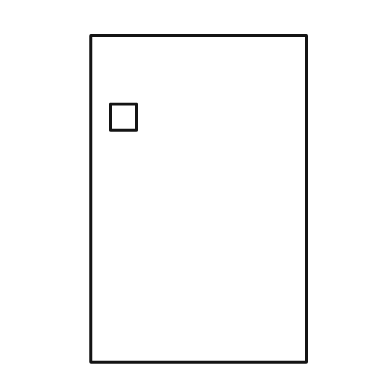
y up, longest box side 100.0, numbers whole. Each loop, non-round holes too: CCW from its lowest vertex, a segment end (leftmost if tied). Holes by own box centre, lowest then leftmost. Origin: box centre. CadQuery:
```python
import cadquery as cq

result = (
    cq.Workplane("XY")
    .moveTo(-33.0, -50.0)
    .lineTo(33.0, -50.0)
    .lineTo(33.0, 50.0)
    .lineTo(-33.0, 50.0)
    .close()
    .moveTo(-27.0, 21.0)
    .lineTo(-19.0, 21.0)
    .lineTo(-19.0, 29.0)
    .lineTo(-27.0, 29.0)
    .close()
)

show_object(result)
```